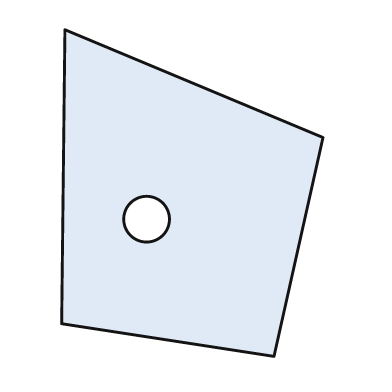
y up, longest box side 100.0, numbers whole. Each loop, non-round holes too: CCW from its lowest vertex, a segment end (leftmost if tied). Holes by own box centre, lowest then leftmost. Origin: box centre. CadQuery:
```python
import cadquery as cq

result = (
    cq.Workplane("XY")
    .moveTo(25.0, -50.0)
    .lineTo(40.0, 17.0)
    .lineTo(-39.0, 50.0)
    .lineTo(-40.0, -40.0)
    .close()
    .moveTo(-14.0, -8.0)
    .circle(7.0)
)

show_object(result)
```